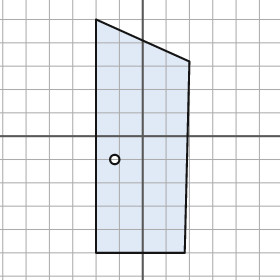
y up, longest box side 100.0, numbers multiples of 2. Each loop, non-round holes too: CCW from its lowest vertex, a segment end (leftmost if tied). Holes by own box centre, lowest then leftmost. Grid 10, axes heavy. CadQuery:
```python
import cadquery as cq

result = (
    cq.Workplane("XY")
    .moveTo(-20.0, -50.0)
    .lineTo(18.0, -50.0)
    .lineTo(20.0, 32.0)
    .lineTo(-20.0, 50.0)
    .close()
    .moveTo(-12.0, -10.0)
    .circle(2.0)
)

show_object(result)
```